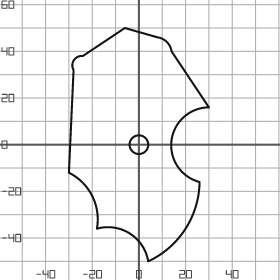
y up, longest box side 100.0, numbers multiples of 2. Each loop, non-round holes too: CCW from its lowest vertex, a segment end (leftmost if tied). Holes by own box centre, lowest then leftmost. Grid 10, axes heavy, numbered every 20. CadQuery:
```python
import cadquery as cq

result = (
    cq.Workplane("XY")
    .moveTo(4.0, -50.0)
    .threePointArc((20.0, -36.0), (26.0, -16.0))
    .threePointArc((14.0, 2.0), (30.0, 16.0))
    .lineTo(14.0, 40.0)
    .threePointArc((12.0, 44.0), (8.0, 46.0))
    .lineTo(-6.0, 50.0)
    .lineTo(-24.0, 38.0)
    .threePointArc((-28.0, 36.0), (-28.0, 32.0))
    .lineTo(-30.0, -12.0)
    .threePointArc((-20.0, -22.0), (-18.0, -36.0))
    .threePointArc((-4.0, -38.0), (4.0, -50.0))
    .close()
    .moveTo(0.0, 0.0)
    .circle(4.0)
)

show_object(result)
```